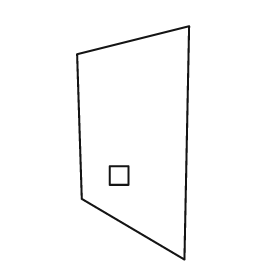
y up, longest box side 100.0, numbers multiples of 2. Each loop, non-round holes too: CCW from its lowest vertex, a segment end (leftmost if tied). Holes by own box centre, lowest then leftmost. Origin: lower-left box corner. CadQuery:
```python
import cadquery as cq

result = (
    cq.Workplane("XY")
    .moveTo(46.0, 0.0)
    .lineTo(48.0, 100.0)
    .lineTo(0.0, 88.0)
    .lineTo(2.0, 26.0)
    .close()
    .moveTo(14.0, 32.0)
    .lineTo(22.0, 32.0)
    .lineTo(22.0, 40.0)
    .lineTo(14.0, 40.0)
    .close()
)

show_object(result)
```